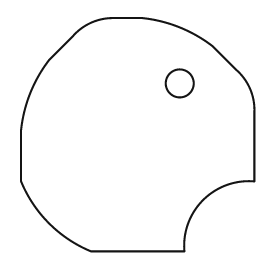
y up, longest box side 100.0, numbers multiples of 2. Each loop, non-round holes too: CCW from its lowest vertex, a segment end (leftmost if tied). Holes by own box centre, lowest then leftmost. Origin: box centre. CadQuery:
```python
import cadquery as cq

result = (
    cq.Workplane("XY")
    .moveTo(-20.0, -50.0)
    .lineTo(20.0, -50.0)
    .threePointArc((28.0, -28.0), (50.0, -20.0))
    .lineTo(50.0, 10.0)
    .threePointArc((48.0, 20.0), (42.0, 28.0))
    .lineTo(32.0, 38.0)
    .threePointArc((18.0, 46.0), (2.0, 50.0))
    .lineTo(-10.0, 50.0)
    .threePointArc((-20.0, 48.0), (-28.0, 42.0))
    .lineTo(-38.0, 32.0)
    .threePointArc((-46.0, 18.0), (-50.0, 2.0))
    .lineTo(-50.0, -20.0)
    .threePointArc((-38.0, -38.0), (-20.0, -50.0))
    .close()
    .moveTo(18.0, 22.0)
    .circle(6.0)
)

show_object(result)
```